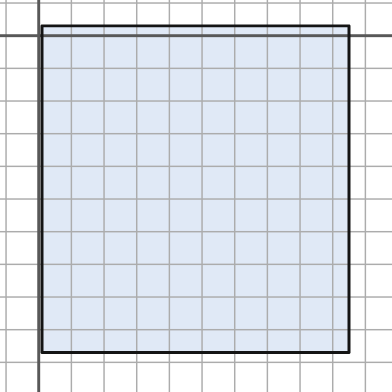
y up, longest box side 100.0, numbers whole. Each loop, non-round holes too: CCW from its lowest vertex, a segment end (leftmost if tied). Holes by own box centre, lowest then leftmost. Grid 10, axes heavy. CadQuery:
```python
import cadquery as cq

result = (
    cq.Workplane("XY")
    .moveTo(1.0, -97.0)
    .lineTo(95.0, -97.0)
    .lineTo(95.0, 3.0)
    .lineTo(1.0, 3.0)
    .close()
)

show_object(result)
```